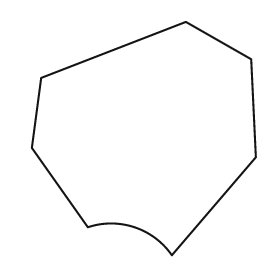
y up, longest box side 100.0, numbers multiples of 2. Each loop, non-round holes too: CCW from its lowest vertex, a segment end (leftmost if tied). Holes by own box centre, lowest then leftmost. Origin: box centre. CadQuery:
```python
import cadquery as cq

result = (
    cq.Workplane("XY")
    .moveTo(12.0, -50.0)
    .lineTo(48.0, -8.0)
    .lineTo(46.0, 34.0)
    .lineTo(18.0, 50.0)
    .lineTo(-44.0, 26.0)
    .lineTo(-48.0, -4.0)
    .lineTo(-24.0, -38.0)
    .threePointArc((-4.0, -38.0), (12.0, -50.0))
    .close()
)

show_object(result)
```